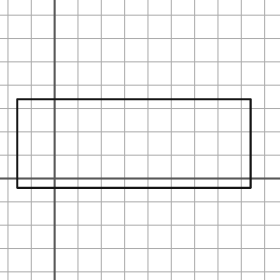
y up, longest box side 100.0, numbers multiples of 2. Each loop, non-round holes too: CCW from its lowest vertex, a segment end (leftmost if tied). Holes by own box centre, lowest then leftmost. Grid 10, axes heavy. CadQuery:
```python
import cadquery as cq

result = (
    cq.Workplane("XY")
    .moveTo(-16.0, -4.0)
    .lineTo(84.0, -4.0)
    .lineTo(84.0, 34.0)
    .lineTo(-16.0, 34.0)
    .close()
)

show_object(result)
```